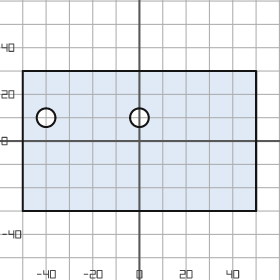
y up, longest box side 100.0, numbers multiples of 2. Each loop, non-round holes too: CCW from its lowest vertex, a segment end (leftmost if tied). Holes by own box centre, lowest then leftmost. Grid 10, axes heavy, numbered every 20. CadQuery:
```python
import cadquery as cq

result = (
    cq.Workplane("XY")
    .moveTo(-50.0, -30.0)
    .lineTo(50.0, -30.0)
    .lineTo(50.0, 30.0)
    .lineTo(-50.0, 30.0)
    .close()
    .moveTo(-40.0, 10.0)
    .circle(4.0)
    .moveTo(0.0, 10.0)
    .circle(4.0)
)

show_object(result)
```